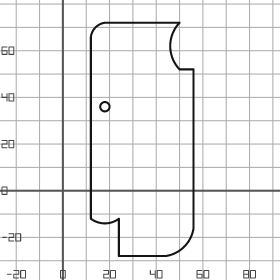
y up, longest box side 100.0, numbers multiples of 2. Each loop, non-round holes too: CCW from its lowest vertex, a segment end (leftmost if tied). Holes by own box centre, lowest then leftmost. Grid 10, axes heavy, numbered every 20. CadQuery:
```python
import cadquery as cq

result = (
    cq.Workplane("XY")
    .moveTo(24.0, -28.0)
    .lineTo(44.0, -28.0)
    .threePointArc((52.0, -24.0), (56.0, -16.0))
    .lineTo(56.0, 52.0)
    .lineTo(50.0, 52.0)
    .threePointArc((46.0, 62.0), (50.0, 72.0))
    .lineTo(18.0, 72.0)
    .threePointArc((14.0, 70.0), (12.0, 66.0))
    .lineTo(12.0, -12.0)
    .threePointArc((18.0, -14.0), (24.0, -12.0))
    .close()
    .moveTo(18.0, 36.0)
    .circle(2.0)
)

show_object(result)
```